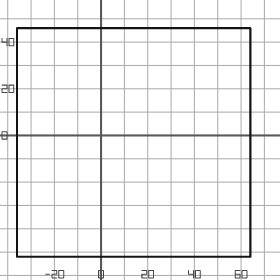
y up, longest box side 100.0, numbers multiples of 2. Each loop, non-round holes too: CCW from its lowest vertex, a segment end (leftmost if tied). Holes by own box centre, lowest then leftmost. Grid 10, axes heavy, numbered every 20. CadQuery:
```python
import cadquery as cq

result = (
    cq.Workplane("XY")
    .moveTo(-36.0, -52.0)
    .lineTo(64.0, -52.0)
    .lineTo(64.0, 46.0)
    .lineTo(-36.0, 46.0)
    .close()
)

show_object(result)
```